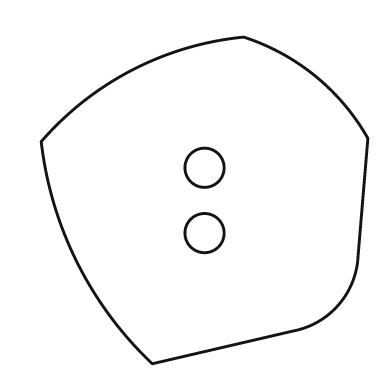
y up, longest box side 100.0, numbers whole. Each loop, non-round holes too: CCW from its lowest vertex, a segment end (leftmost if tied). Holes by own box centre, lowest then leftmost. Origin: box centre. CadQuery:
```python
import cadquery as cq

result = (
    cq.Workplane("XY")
    .moveTo(-16.0, -50.0)
    .lineTo(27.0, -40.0)
    .threePointArc((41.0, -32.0), (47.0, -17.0))
    .lineTo(50.0, 19.0)
    .threePointArc((34.0, 38.0), (12.0, 50.0))
    .threePointArc((-22.0, 40.0), (-50.0, 18.0))
    .threePointArc((-39.0, -19.0), (-16.0, -50.0))
    .close()
    .moveTo(0.0, -10.0)
    .circle(6.0)
    .moveTo(0.0, 10.0)
    .circle(6.0)
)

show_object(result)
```